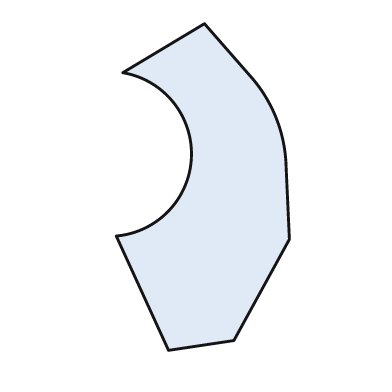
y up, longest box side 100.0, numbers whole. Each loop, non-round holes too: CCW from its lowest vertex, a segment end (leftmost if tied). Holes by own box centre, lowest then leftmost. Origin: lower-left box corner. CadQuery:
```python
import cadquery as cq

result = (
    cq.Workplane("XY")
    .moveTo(16.0, 0.0)
    .lineTo(36.0, 3.0)
    .lineTo(53.0, 34.0)
    .lineTo(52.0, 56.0)
    .threePointArc((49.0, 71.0), (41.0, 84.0))
    .lineTo(27.0, 100.0)
    .lineTo(2.0, 85.0)
    .threePointArc((23.0, 59.0), (0.0, 35.0))
    .close()
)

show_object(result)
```